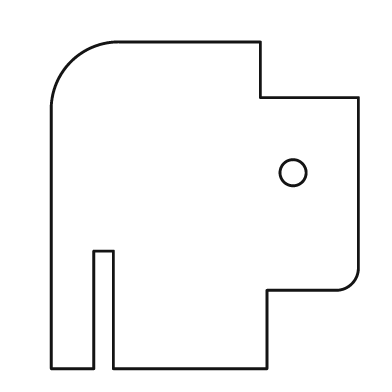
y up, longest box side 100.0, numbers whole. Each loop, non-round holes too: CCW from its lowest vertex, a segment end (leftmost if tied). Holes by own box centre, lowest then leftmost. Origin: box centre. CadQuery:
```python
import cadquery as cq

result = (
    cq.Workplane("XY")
    .moveTo(-47.0, -50.0)
    .lineTo(-34.0, -50.0)
    .lineTo(-34.0, -14.0)
    .lineTo(-28.0, -14.0)
    .lineTo(-28.0, -50.0)
    .lineTo(19.0, -50.0)
    .lineTo(19.0, -26.0)
    .lineTo(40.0, -26.0)
    .threePointArc((45.0, -24.0), (47.0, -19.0))
    .lineTo(47.0, 33.0)
    .lineTo(17.0, 33.0)
    .lineTo(17.0, 50.0)
    .lineTo(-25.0, 50.0)
    .threePointArc((-41.0, 44.0), (-47.0, 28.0))
    .close()
    .moveTo(27.0, 10.0)
    .circle(4.0)
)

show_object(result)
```